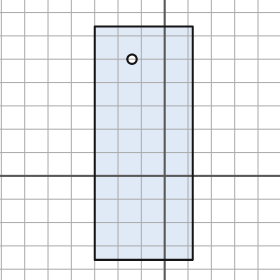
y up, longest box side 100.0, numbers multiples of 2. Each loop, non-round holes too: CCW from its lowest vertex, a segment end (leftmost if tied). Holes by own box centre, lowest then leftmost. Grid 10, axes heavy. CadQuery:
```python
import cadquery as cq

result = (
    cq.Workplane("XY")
    .moveTo(-30.0, -36.0)
    .lineTo(12.0, -36.0)
    .lineTo(12.0, 64.0)
    .lineTo(-30.0, 64.0)
    .close()
    .moveTo(-14.0, 50.0)
    .circle(2.0)
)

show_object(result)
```